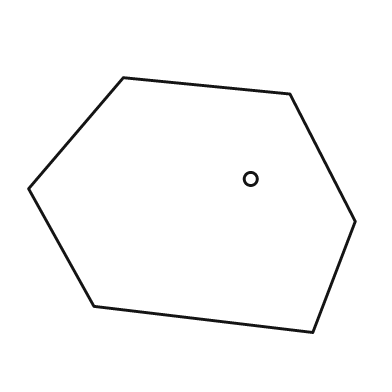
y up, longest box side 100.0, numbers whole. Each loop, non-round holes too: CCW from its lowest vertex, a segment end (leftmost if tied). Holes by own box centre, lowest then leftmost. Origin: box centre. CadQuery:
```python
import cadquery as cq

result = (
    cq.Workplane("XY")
    .moveTo(37.0, -39.0)
    .lineTo(50.0, -5.0)
    .lineTo(30.0, 34.0)
    .lineTo(-21.0, 39.0)
    .lineTo(-50.0, 5.0)
    .lineTo(-30.0, -31.0)
    .close()
    .moveTo(18.0, 8.0)
    .circle(2.0)
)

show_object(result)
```